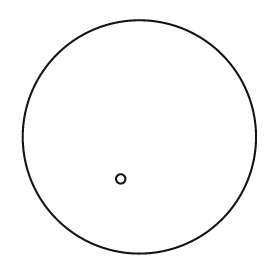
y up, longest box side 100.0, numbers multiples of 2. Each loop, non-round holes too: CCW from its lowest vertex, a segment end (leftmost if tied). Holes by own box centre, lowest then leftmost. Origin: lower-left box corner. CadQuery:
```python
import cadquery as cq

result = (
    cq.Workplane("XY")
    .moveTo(50.0, 50.0)
    .circle(50.0)
    .moveTo(42.0, 32.0)
    .circle(2.0)
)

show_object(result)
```